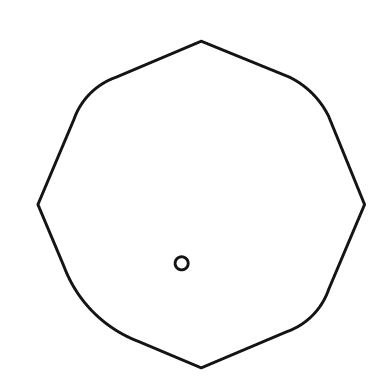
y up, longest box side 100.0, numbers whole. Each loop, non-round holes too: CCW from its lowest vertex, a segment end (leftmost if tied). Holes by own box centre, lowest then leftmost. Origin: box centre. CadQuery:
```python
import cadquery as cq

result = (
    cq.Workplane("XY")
    .moveTo(0.0, -50.0)
    .lineTo(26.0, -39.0)
    .threePointArc((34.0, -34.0), (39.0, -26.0))
    .lineTo(50.0, 0.0)
    .lineTo(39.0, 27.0)
    .threePointArc((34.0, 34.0), (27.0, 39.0))
    .lineTo(0.0, 50.0)
    .lineTo(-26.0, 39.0)
    .threePointArc((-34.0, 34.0), (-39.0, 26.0))
    .lineTo(-50.0, 0.0)
    .lineTo(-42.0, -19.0)
    .threePointArc((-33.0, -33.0), (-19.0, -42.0))
    .close()
    .moveTo(-6.0, -18.0)
    .circle(2.0)
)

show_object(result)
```